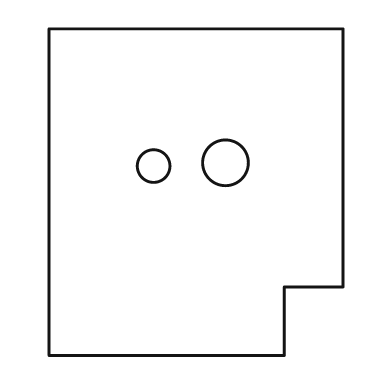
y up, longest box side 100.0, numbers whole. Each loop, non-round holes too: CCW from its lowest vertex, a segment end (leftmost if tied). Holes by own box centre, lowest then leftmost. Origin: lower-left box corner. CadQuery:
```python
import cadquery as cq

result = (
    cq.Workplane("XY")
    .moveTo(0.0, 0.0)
    .lineTo(72.0, 0.0)
    .lineTo(72.0, 21.0)
    .lineTo(90.0, 21.0)
    .lineTo(90.0, 100.0)
    .lineTo(0.0, 100.0)
    .close()
    .moveTo(32.0, 58.0)
    .circle(5.0)
    .moveTo(54.0, 59.0)
    .circle(7.0)
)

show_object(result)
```